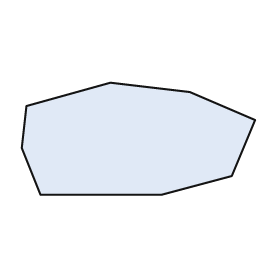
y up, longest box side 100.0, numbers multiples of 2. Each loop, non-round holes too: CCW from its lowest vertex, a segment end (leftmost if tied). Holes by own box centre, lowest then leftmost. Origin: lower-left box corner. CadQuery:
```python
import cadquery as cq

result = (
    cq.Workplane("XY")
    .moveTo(8.0, 0.0)
    .lineTo(60.0, 0.0)
    .lineTo(90.0, 8.0)
    .lineTo(100.0, 32.0)
    .lineTo(72.0, 44.0)
    .lineTo(38.0, 48.0)
    .lineTo(2.0, 38.0)
    .lineTo(0.0, 20.0)
    .close()
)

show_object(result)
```